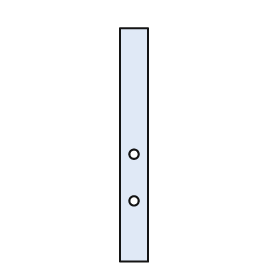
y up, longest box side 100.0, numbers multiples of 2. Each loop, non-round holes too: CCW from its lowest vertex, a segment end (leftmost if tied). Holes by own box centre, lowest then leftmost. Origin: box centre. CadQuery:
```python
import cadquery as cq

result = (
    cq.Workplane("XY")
    .moveTo(-6.0, -50.0)
    .lineTo(6.0, -50.0)
    .lineTo(6.0, 50.0)
    .lineTo(-6.0, 50.0)
    .close()
    .moveTo(0.0, -24.0)
    .circle(2.0)
    .moveTo(0.0, -4.0)
    .circle(2.0)
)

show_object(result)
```